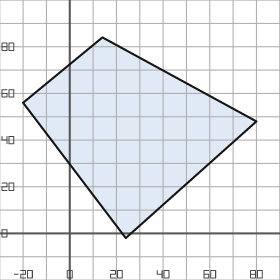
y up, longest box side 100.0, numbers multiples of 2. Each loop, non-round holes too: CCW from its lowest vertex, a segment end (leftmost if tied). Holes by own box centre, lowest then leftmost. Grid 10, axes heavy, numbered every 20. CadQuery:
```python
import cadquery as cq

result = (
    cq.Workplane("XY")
    .moveTo(24.0, -2.0)
    .lineTo(80.0, 48.0)
    .lineTo(14.0, 84.0)
    .lineTo(-20.0, 56.0)
    .close()
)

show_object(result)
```